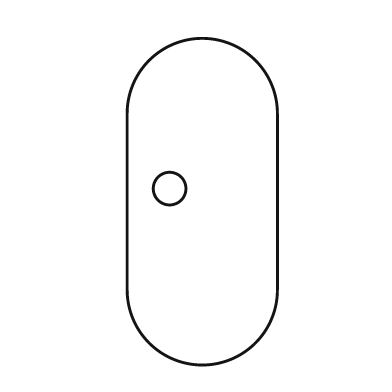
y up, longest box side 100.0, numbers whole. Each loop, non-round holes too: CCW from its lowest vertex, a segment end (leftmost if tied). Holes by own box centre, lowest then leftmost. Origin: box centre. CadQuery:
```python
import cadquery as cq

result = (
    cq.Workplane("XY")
    .moveTo(-23.0, -27.0)
    .threePointArc((0.0, -50.0), (23.0, -27.0))
    .lineTo(23.0, 27.0)
    .threePointArc((0.0, 50.0), (-23.0, 27.0))
    .close()
    .moveTo(-10.0, 4.0)
    .circle(5.0)
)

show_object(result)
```